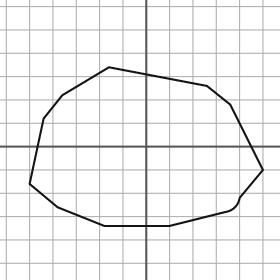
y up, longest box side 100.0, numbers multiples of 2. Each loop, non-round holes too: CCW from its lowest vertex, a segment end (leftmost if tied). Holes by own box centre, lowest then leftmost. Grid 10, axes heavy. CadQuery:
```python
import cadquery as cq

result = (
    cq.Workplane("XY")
    .moveTo(-18.0, -34.0)
    .lineTo(10.0, -34.0)
    .lineTo(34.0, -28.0)
    .threePointArc((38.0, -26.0), (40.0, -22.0))
    .lineTo(50.0, -10.0)
    .lineTo(36.0, 18.0)
    .lineTo(26.0, 26.0)
    .lineTo(-16.0, 34.0)
    .lineTo(-36.0, 22.0)
    .lineTo(-44.0, 12.0)
    .lineTo(-50.0, -16.0)
    .lineTo(-38.0, -26.0)
    .close()
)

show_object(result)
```